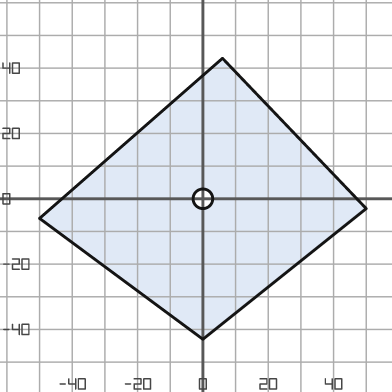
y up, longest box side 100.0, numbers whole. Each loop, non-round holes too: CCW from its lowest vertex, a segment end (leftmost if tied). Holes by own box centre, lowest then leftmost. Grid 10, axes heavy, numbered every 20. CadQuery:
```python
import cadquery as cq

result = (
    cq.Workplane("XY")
    .moveTo(0.0, -43.0)
    .lineTo(50.0, -3.0)
    .lineTo(6.0, 43.0)
    .lineTo(-50.0, -6.0)
    .close()
    .moveTo(0.0, 0.0)
    .circle(3.0)
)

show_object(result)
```